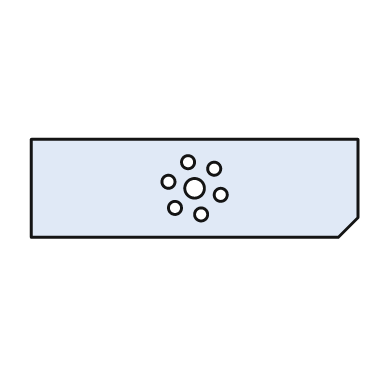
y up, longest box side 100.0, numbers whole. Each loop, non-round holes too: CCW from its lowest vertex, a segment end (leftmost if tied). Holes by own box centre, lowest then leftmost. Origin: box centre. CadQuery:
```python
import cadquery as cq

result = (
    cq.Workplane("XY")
    .moveTo(-50.0, -15.0)
    .lineTo(44.0, -15.0)
    .lineTo(50.0, -9.0)
    .lineTo(50.0, 15.0)
    .lineTo(-50.0, 15.0)
    .close()
    .moveTo(2.0, -8.0)
    .circle(2.0)
    .moveTo(-6.0, -6.0)
    .circle(2.0)
    .moveTo(8.0, -2.0)
    .circle(2.0)
    .moveTo(0.0, 0.0)
    .circle(3.0)
    .moveTo(-8.0, 2.0)
    .circle(2.0)
    .moveTo(6.0, 6.0)
    .circle(2.0)
    .moveTo(-2.0, 8.0)
    .circle(2.0)
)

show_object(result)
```